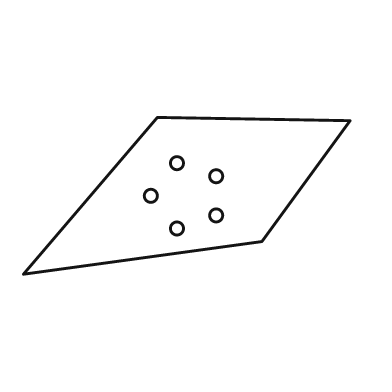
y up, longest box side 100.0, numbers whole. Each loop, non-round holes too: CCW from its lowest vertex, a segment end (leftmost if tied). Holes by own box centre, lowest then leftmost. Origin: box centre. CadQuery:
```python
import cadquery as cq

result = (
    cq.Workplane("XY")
    .moveTo(-50.0, -24.0)
    .lineTo(23.0, -14.0)
    .lineTo(50.0, 23.0)
    .lineTo(-9.0, 24.0)
    .close()
    .moveTo(-3.0, -10.0)
    .circle(2.0)
    .moveTo(9.0, -6.0)
    .circle(2.0)
    .moveTo(-11.0, 0.0)
    .circle(2.0)
    .moveTo(9.0, 6.0)
    .circle(2.0)
    .moveTo(-3.0, 10.0)
    .circle(2.0)
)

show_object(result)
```